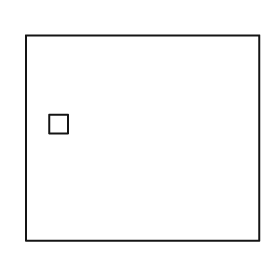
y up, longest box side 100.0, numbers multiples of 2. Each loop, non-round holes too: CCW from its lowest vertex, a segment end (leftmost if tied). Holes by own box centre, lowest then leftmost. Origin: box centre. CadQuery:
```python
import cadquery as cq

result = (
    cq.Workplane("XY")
    .moveTo(-50.0, -44.0)
    .lineTo(50.0, -44.0)
    .lineTo(50.0, 44.0)
    .lineTo(-50.0, 44.0)
    .close()
    .moveTo(-40.0, 2.0)
    .lineTo(-32.0, 2.0)
    .lineTo(-32.0, 10.0)
    .lineTo(-40.0, 10.0)
    .close()
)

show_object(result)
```